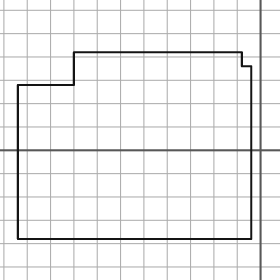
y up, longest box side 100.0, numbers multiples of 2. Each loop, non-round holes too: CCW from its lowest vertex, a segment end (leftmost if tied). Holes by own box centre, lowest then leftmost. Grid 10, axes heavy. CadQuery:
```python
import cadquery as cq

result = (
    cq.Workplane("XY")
    .moveTo(-104.0, -38.0)
    .lineTo(-4.0, -38.0)
    .lineTo(-4.0, 36.0)
    .lineTo(-8.0, 36.0)
    .lineTo(-8.0, 42.0)
    .lineTo(-80.0, 42.0)
    .lineTo(-80.0, 28.0)
    .lineTo(-104.0, 28.0)
    .close()
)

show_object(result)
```